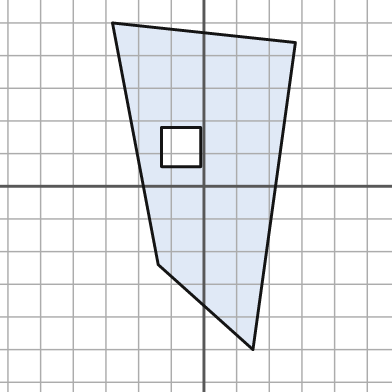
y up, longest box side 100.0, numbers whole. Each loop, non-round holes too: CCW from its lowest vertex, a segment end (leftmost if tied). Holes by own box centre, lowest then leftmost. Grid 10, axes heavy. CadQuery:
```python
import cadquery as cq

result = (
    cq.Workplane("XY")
    .moveTo(15.0, -50.0)
    .lineTo(28.0, 44.0)
    .lineTo(-28.0, 50.0)
    .lineTo(-14.0, -24.0)
    .close()
    .moveTo(-13.0, 6.0)
    .lineTo(-1.0, 6.0)
    .lineTo(-1.0, 18.0)
    .lineTo(-13.0, 18.0)
    .close()
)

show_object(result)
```